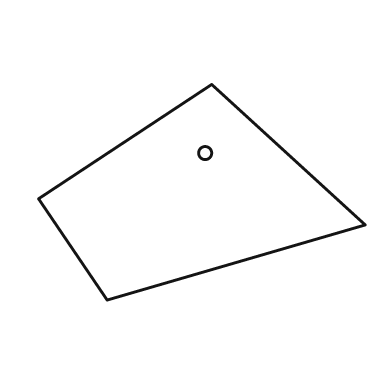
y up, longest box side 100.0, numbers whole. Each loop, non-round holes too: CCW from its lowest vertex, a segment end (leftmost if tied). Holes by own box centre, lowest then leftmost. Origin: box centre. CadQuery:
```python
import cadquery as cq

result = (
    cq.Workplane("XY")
    .moveTo(-29.0, -33.0)
    .lineTo(50.0, -10.0)
    .lineTo(3.0, 33.0)
    .lineTo(-50.0, -2.0)
    .close()
    .moveTo(1.0, 12.0)
    .circle(2.0)
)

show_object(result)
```